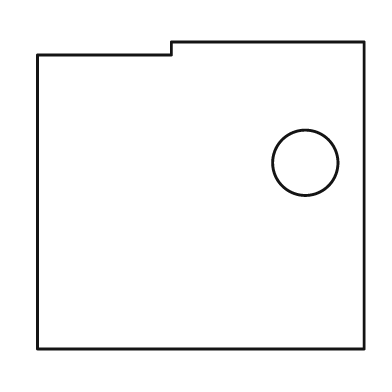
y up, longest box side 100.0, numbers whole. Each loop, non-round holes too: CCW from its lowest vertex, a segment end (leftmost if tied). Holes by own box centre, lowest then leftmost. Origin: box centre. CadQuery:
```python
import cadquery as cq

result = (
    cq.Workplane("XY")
    .moveTo(-50.0, -47.0)
    .lineTo(50.0, -47.0)
    .lineTo(50.0, 47.0)
    .lineTo(-9.0, 47.0)
    .lineTo(-9.0, 43.0)
    .lineTo(-50.0, 43.0)
    .close()
    .moveTo(32.0, 10.0)
    .circle(10.0)
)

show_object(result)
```